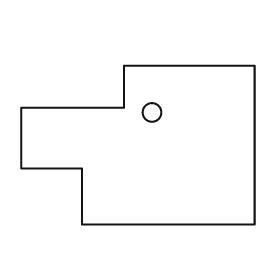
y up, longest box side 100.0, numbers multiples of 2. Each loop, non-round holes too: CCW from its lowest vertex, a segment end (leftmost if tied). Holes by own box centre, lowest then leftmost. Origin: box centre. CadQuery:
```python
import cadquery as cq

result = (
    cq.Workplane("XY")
    .moveTo(-24.0, -34.0)
    .lineTo(50.0, -34.0)
    .lineTo(50.0, 34.0)
    .lineTo(-6.0, 34.0)
    .lineTo(-6.0, 16.0)
    .lineTo(-50.0, 16.0)
    .lineTo(-50.0, -10.0)
    .lineTo(-24.0, -10.0)
    .close()
    .moveTo(6.0, 14.0)
    .circle(4.0)
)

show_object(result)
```